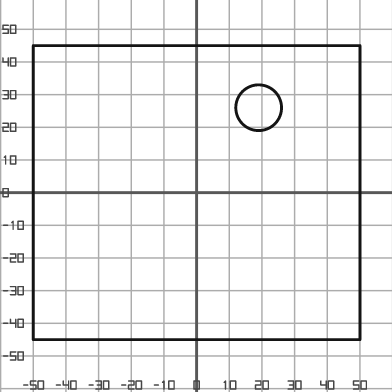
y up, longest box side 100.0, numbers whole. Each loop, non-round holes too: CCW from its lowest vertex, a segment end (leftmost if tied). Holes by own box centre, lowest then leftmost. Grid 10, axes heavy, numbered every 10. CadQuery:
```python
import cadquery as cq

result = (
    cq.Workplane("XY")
    .moveTo(-50.0, -45.0)
    .lineTo(50.0, -45.0)
    .lineTo(50.0, 45.0)
    .lineTo(-50.0, 45.0)
    .close()
    .moveTo(19.0, 26.0)
    .circle(7.0)
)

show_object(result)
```